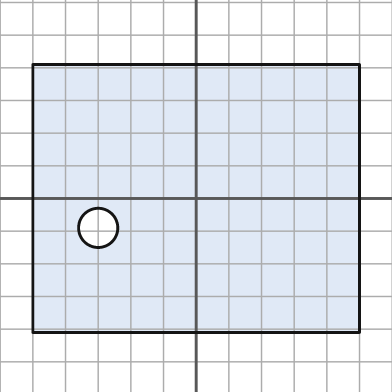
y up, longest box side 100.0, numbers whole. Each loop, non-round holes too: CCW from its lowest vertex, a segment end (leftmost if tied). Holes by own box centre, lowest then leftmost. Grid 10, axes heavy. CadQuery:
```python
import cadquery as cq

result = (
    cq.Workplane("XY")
    .moveTo(-50.0, -41.0)
    .lineTo(50.0, -41.0)
    .lineTo(50.0, 41.0)
    .lineTo(-50.0, 41.0)
    .close()
    .moveTo(-30.0, -9.0)
    .circle(6.0)
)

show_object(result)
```